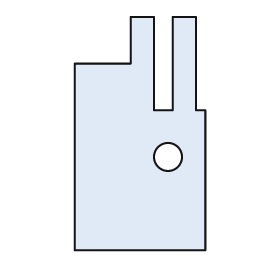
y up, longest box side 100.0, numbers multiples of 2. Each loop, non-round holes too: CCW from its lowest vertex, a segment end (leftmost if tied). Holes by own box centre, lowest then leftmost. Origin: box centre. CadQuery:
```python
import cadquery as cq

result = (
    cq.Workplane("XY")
    .moveTo(-28.0, -50.0)
    .lineTo(28.0, -50.0)
    .lineTo(28.0, 10.0)
    .lineTo(24.0, 10.0)
    .lineTo(24.0, 50.0)
    .lineTo(14.0, 50.0)
    .lineTo(14.0, 10.0)
    .lineTo(6.0, 10.0)
    .lineTo(6.0, 50.0)
    .lineTo(-4.0, 50.0)
    .lineTo(-4.0, 30.0)
    .lineTo(-28.0, 30.0)
    .close()
    .moveTo(12.0, -10.0)
    .circle(6.0)
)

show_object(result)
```